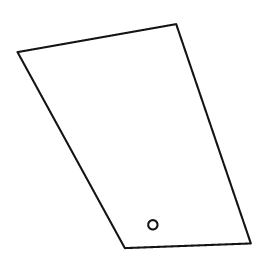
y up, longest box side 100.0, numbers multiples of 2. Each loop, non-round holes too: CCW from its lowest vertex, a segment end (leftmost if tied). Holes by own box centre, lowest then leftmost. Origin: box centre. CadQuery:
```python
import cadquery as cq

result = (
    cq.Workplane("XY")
    .moveTo(-4.0, -48.0)
    .lineTo(50.0, -46.0)
    .lineTo(18.0, 48.0)
    .lineTo(-50.0, 36.0)
    .close()
    .moveTo(8.0, -38.0)
    .circle(2.0)
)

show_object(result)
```